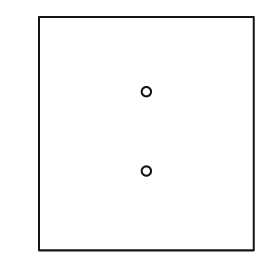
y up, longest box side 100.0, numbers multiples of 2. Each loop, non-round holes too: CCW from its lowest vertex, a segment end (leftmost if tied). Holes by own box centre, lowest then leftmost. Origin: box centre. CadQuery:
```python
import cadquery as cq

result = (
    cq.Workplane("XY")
    .moveTo(-46.0, -50.0)
    .lineTo(46.0, -50.0)
    .lineTo(46.0, 50.0)
    .lineTo(-46.0, 50.0)
    .close()
    .moveTo(0.0, -16.0)
    .circle(2.0)
    .moveTo(0.0, 18.0)
    .circle(2.0)
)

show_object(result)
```